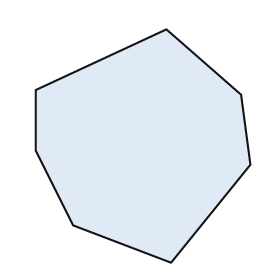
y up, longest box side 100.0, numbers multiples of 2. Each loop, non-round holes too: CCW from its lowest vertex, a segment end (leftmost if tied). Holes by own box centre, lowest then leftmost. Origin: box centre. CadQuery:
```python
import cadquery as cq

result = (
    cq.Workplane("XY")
    .moveTo(12.0, -50.0)
    .lineTo(46.0, -8.0)
    .lineTo(42.0, 22.0)
    .lineTo(10.0, 50.0)
    .lineTo(-46.0, 24.0)
    .lineTo(-46.0, -2.0)
    .lineTo(-30.0, -34.0)
    .close()
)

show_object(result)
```